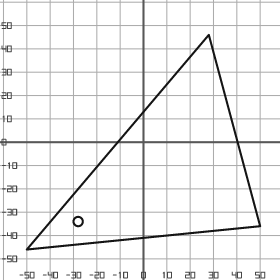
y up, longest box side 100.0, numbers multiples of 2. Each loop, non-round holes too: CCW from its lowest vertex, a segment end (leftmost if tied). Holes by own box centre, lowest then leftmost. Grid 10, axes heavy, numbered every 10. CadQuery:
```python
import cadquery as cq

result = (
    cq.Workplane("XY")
    .moveTo(-50.0, -46.0)
    .lineTo(50.0, -36.0)
    .lineTo(28.0, 46.0)
    .close()
    .moveTo(-28.0, -34.0)
    .circle(2.0)
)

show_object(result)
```